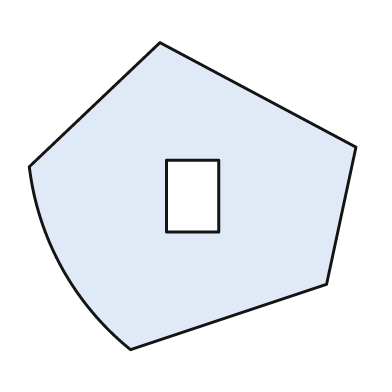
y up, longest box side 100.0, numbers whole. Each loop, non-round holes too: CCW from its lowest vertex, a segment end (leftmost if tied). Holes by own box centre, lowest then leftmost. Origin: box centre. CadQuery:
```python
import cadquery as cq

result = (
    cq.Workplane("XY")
    .moveTo(-19.0, -47.0)
    .lineTo(41.0, -27.0)
    .lineTo(50.0, 15.0)
    .lineTo(-10.0, 47.0)
    .lineTo(-50.0, 9.0)
    .threePointArc((-40.0, -22.0), (-19.0, -47.0))
    .close()
    .moveTo(-8.0, -11.0)
    .lineTo(8.0, -11.0)
    .lineTo(8.0, 11.0)
    .lineTo(-8.0, 11.0)
    .close()
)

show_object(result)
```